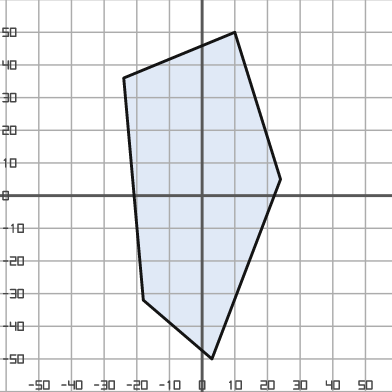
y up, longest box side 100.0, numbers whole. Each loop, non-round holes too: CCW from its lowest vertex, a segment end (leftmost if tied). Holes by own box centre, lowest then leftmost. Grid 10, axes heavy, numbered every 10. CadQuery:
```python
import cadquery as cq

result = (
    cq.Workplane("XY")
    .moveTo(3.0, -50.0)
    .lineTo(24.0, 5.0)
    .lineTo(10.0, 50.0)
    .lineTo(-24.0, 36.0)
    .lineTo(-18.0, -32.0)
    .close()
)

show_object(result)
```